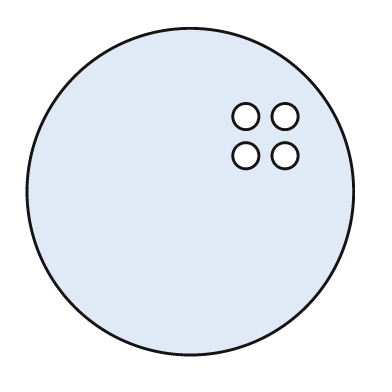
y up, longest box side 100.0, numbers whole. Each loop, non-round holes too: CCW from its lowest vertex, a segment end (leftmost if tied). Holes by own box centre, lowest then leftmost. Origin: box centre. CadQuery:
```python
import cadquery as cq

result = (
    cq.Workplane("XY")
    .moveTo(0.0, 0.0)
    .circle(50.0)
    .moveTo(17.0, 11.0)
    .circle(4.0)
    .moveTo(29.0, 11.0)
    .circle(4.0)
    .moveTo(17.0, 23.0)
    .circle(4.0)
    .moveTo(29.0, 23.0)
    .circle(4.0)
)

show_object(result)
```